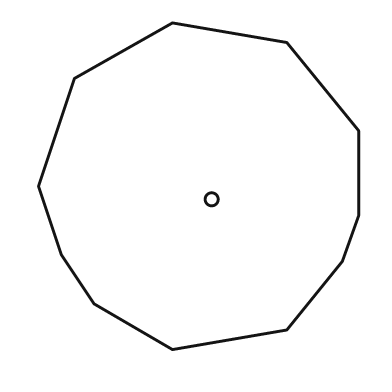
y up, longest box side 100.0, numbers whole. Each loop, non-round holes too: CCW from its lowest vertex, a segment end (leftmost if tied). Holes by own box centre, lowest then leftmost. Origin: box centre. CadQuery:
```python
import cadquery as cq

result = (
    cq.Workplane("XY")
    .moveTo(-8.0, -50.0)
    .lineTo(27.0, -44.0)
    .lineTo(44.0, -23.0)
    .lineTo(49.0, -9.0)
    .lineTo(49.0, 17.0)
    .lineTo(27.0, 44.0)
    .lineTo(-8.0, 50.0)
    .lineTo(-38.0, 33.0)
    .lineTo(-49.0, 0.0)
    .lineTo(-42.0, -21.0)
    .lineTo(-32.0, -36.0)
    .close()
    .moveTo(4.0, -4.0)
    .circle(2.0)
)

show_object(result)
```